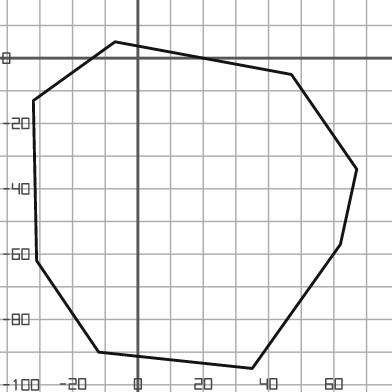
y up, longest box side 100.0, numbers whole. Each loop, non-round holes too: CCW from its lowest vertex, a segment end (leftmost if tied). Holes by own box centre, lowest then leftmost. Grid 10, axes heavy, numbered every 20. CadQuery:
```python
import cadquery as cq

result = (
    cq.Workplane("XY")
    .moveTo(35.0, -95.0)
    .lineTo(62.0, -57.0)
    .lineTo(67.0, -34.0)
    .lineTo(47.0, -5.0)
    .lineTo(-7.0, 5.0)
    .lineTo(-32.0, -13.0)
    .lineTo(-31.0, -62.0)
    .lineTo(-12.0, -90.0)
    .close()
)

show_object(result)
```